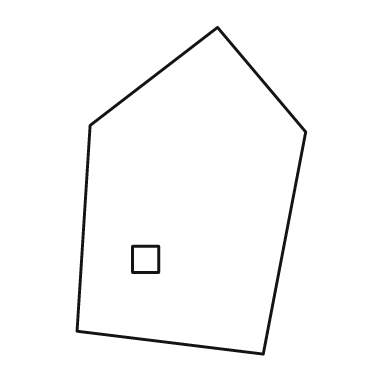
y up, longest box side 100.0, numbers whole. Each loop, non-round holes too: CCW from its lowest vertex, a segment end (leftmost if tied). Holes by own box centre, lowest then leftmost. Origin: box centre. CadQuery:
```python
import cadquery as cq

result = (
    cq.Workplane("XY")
    .moveTo(22.0, -50.0)
    .lineTo(35.0, 18.0)
    .lineTo(8.0, 50.0)
    .lineTo(-31.0, 20.0)
    .lineTo(-35.0, -43.0)
    .close()
    .moveTo(-18.0, -25.0)
    .lineTo(-10.0, -25.0)
    .lineTo(-10.0, -17.0)
    .lineTo(-18.0, -17.0)
    .close()
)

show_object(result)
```